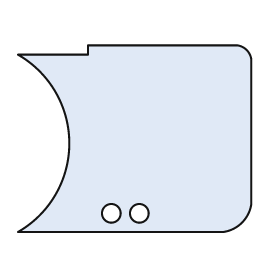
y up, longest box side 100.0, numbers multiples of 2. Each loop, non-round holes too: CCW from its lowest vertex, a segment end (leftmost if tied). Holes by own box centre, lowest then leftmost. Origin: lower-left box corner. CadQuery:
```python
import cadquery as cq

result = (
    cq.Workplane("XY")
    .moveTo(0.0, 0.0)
    .lineTo(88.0, 0.0)
    .threePointArc((96.0, 4.0), (100.0, 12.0))
    .lineTo(100.0, 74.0)
    .threePointArc((98.0, 78.0), (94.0, 80.0))
    .lineTo(30.0, 80.0)
    .lineTo(30.0, 76.0)
    .lineTo(0.0, 76.0)
    .threePointArc((22.0, 38.0), (0.0, 0.0))
    .close()
    .moveTo(40.0, 8.0)
    .circle(4.0)
    .moveTo(52.0, 8.0)
    .circle(4.0)
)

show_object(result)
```